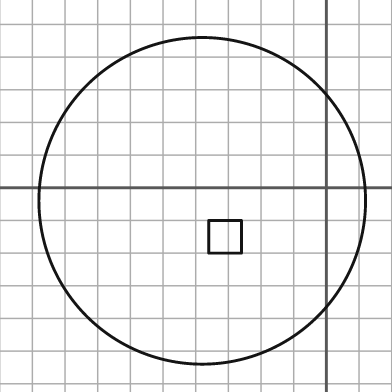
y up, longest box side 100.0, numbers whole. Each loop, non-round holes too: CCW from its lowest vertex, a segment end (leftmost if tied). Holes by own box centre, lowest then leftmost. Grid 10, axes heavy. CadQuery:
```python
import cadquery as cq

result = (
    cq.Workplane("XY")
    .moveTo(-38.0, -4.0)
    .circle(50.0)
    .moveTo(-36.0, -20.0)
    .lineTo(-26.0, -20.0)
    .lineTo(-26.0, -10.0)
    .lineTo(-36.0, -10.0)
    .close()
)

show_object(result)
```